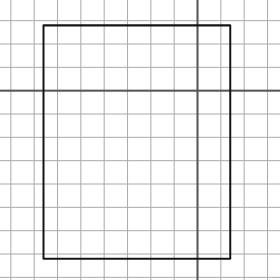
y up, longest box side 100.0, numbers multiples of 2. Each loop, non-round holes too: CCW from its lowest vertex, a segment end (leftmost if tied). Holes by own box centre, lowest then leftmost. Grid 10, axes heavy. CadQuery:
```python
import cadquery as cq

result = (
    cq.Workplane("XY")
    .moveTo(-66.0, -72.0)
    .lineTo(14.0, -72.0)
    .lineTo(14.0, 28.0)
    .lineTo(-66.0, 28.0)
    .close()
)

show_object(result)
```